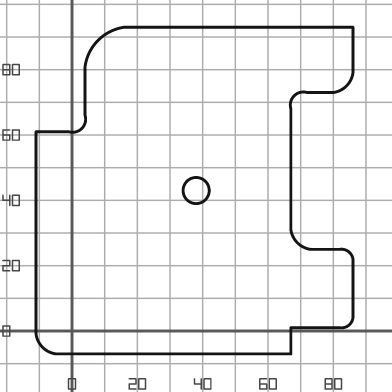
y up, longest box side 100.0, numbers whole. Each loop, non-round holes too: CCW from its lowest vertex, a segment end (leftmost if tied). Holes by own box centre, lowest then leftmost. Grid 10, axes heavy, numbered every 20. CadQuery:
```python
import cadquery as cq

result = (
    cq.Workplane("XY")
    .moveTo(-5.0, -7.0)
    .lineTo(67.0, -7.0)
    .lineTo(67.0, 1.0)
    .lineTo(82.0, 1.0)
    .threePointArc((85.0, 2.0), (86.0, 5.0))
    .lineTo(86.0, 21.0)
    .threePointArc((85.0, 24.0), (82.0, 25.0))
    .lineTo(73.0, 25.0)
    .threePointArc((69.0, 27.0), (67.0, 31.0))
    .lineTo(67.0, 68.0)
    .threePointArc((68.0, 72.0), (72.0, 73.0))
    .lineTo(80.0, 73.0)
    .threePointArc((84.0, 75.0), (86.0, 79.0))
    .lineTo(86.0, 93.0)
    .lineTo(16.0, 93.0)
    .threePointArc((8.0, 89.0), (4.0, 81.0))
    .lineTo(4.0, 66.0)
    .threePointArc((3.0, 62.0), (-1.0, 61.0))
    .lineTo(-11.0, 61.0)
    .lineTo(-11.0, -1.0)
    .threePointArc((-9.0, -5.0), (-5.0, -7.0))
    .close()
    .moveTo(38.0, 43.0)
    .circle(4.0)
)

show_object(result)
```